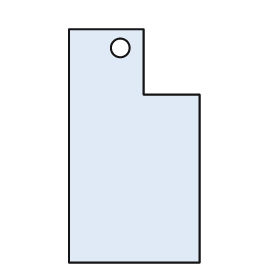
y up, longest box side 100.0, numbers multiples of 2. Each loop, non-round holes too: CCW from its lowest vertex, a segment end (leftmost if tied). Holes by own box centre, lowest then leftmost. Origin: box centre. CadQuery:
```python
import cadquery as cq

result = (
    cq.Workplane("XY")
    .moveTo(-28.0, -50.0)
    .lineTo(28.0, -50.0)
    .lineTo(28.0, 22.0)
    .lineTo(4.0, 22.0)
    .lineTo(4.0, 50.0)
    .lineTo(-28.0, 50.0)
    .close()
    .moveTo(-6.0, 42.0)
    .circle(4.0)
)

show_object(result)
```